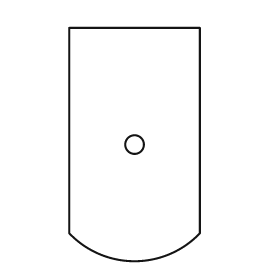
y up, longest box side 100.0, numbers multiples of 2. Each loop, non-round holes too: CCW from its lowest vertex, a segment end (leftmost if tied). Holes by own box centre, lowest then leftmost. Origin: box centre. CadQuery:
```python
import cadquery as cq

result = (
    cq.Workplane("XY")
    .moveTo(-28.0, -38.0)
    .threePointArc((0.0, -50.0), (28.0, -38.0))
    .lineTo(28.0, 50.0)
    .lineTo(-28.0, 50.0)
    .close()
    .moveTo(0.0, 0.0)
    .circle(4.0)
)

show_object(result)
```